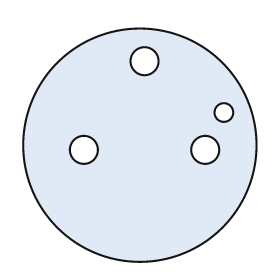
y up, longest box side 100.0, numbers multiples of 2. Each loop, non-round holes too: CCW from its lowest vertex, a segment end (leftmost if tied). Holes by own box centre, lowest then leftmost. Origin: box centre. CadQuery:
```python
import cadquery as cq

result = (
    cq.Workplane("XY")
    .moveTo(0.0, 0.0)
    .circle(50.0)
    .moveTo(-24.0, -2.0)
    .circle(6.0)
    .moveTo(28.0, -2.0)
    .circle(6.0)
    .moveTo(36.0, 14.0)
    .circle(4.0)
    .moveTo(2.0, 36.0)
    .circle(6.0)
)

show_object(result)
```